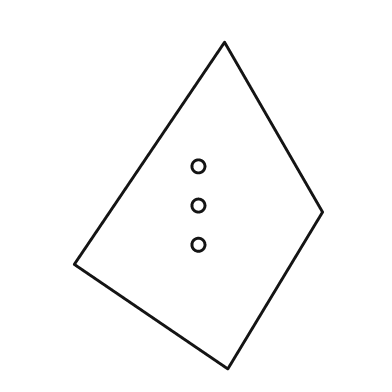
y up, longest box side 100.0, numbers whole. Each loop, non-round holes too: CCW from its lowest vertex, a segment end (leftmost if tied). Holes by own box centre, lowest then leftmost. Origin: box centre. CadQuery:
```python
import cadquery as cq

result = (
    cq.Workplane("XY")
    .moveTo(9.0, -50.0)
    .lineTo(38.0, -2.0)
    .lineTo(8.0, 50.0)
    .lineTo(-38.0, -18.0)
    .close()
    .moveTo(0.0, -12.0)
    .circle(2.0)
    .moveTo(0.0, 0.0)
    .circle(2.0)
    .moveTo(0.0, 12.0)
    .circle(2.0)
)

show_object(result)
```